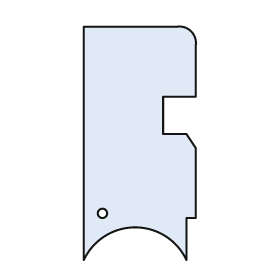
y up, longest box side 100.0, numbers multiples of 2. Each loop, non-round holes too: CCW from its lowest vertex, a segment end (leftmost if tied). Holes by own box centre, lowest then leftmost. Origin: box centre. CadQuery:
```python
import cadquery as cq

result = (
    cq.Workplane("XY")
    .moveTo(-24.0, -50.0)
    .threePointArc((-2.0, -36.0), (20.0, -50.0))
    .lineTo(20.0, -32.0)
    .lineTo(24.0, -32.0)
    .lineTo(24.0, -2.0)
    .lineTo(20.0, 4.0)
    .lineTo(10.0, 4.0)
    .lineTo(10.0, 20.0)
    .lineTo(24.0, 20.0)
    .lineTo(24.0, 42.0)
    .threePointArc((22.0, 48.0), (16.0, 50.0))
    .lineTo(-24.0, 50.0)
    .close()
    .moveTo(-16.0, -30.0)
    .circle(2.0)
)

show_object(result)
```